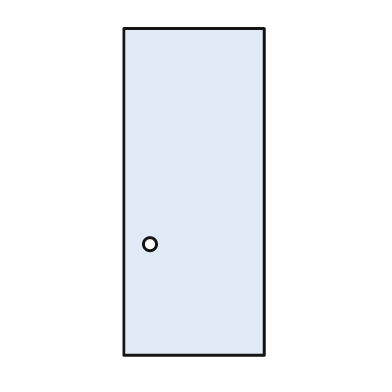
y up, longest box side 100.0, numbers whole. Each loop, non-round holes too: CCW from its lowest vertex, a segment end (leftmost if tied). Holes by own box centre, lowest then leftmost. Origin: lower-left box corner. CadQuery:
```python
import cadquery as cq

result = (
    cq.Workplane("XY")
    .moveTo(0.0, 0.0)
    .lineTo(43.0, 0.0)
    .lineTo(43.0, 100.0)
    .lineTo(0.0, 100.0)
    .close()
    .moveTo(8.0, 34.0)
    .circle(2.0)
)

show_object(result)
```